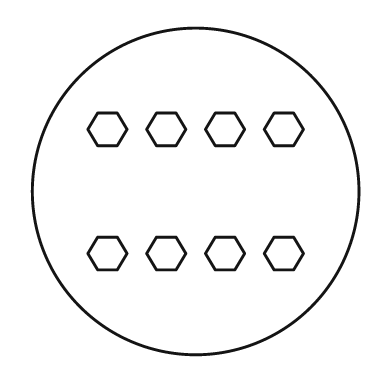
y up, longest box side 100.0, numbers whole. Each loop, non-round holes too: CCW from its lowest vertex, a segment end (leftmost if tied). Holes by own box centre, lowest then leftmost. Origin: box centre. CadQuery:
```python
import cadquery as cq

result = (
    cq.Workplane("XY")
    .moveTo(0.0, 0.0)
    .circle(50.0)
    .moveTo(-30.0, -24.0)
    .lineTo(-24.0, -24.0)
    .lineTo(-21.0, -19.0)
    .lineTo(-24.0, -14.0)
    .lineTo(-30.0, -14.0)
    .lineTo(-33.0, -19.0)
    .close()
    .moveTo(-12.0, -24.0)
    .lineTo(-6.0, -24.0)
    .lineTo(-3.0, -19.0)
    .lineTo(-6.0, -14.0)
    .lineTo(-12.0, -14.0)
    .lineTo(-15.0, -19.0)
    .close()
    .moveTo(6.0, -24.0)
    .lineTo(12.0, -24.0)
    .lineTo(15.0, -19.0)
    .lineTo(12.0, -14.0)
    .lineTo(6.0, -14.0)
    .lineTo(3.0, -19.0)
    .close()
    .moveTo(24.0, -24.0)
    .lineTo(30.0, -24.0)
    .lineTo(33.0, -19.0)
    .lineTo(30.0, -14.0)
    .lineTo(24.0, -14.0)
    .lineTo(21.0, -19.0)
    .close()
    .moveTo(-30.0, 14.0)
    .lineTo(-24.0, 14.0)
    .lineTo(-21.0, 19.0)
    .lineTo(-24.0, 24.0)
    .lineTo(-30.0, 24.0)
    .lineTo(-33.0, 19.0)
    .close()
    .moveTo(-12.0, 14.0)
    .lineTo(-6.0, 14.0)
    .lineTo(-3.0, 19.0)
    .lineTo(-6.0, 24.0)
    .lineTo(-12.0, 24.0)
    .lineTo(-15.0, 19.0)
    .close()
    .moveTo(6.0, 14.0)
    .lineTo(12.0, 14.0)
    .lineTo(15.0, 19.0)
    .lineTo(12.0, 24.0)
    .lineTo(6.0, 24.0)
    .lineTo(3.0, 19.0)
    .close()
    .moveTo(24.0, 14.0)
    .lineTo(30.0, 14.0)
    .lineTo(33.0, 19.0)
    .lineTo(30.0, 24.0)
    .lineTo(24.0, 24.0)
    .lineTo(21.0, 19.0)
    .close()
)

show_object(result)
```